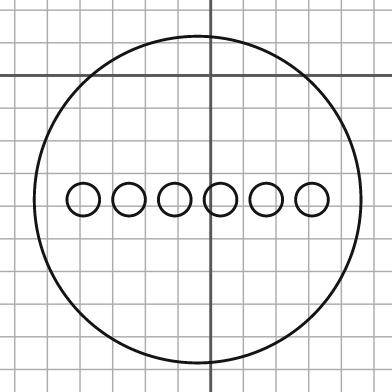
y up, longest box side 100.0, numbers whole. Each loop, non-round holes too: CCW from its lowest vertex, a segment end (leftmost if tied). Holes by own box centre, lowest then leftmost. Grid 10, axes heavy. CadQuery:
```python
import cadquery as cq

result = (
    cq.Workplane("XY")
    .moveTo(-4.0, -38.0)
    .circle(50.0)
    .moveTo(-39.0, -38.0)
    .circle(5.0)
    .moveTo(-25.0, -38.0)
    .circle(5.0)
    .moveTo(-11.0, -38.0)
    .circle(5.0)
    .moveTo(3.0, -38.0)
    .circle(5.0)
    .moveTo(17.0, -38.0)
    .circle(5.0)
    .moveTo(31.0, -38.0)
    .circle(5.0)
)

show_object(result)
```